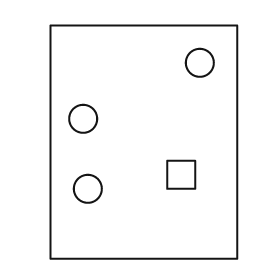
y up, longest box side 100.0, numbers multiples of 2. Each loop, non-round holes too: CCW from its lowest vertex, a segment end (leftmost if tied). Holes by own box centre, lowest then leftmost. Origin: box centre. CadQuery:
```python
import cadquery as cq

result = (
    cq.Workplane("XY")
    .moveTo(-40.0, -50.0)
    .lineTo(40.0, -50.0)
    .lineTo(40.0, 50.0)
    .lineTo(-40.0, 50.0)
    .close()
    .moveTo(-24.0, -20.0)
    .circle(6.0)
    .moveTo(10.0, -20.0)
    .lineTo(22.0, -20.0)
    .lineTo(22.0, -8.0)
    .lineTo(10.0, -8.0)
    .close()
    .moveTo(-26.0, 10.0)
    .circle(6.0)
    .moveTo(24.0, 34.0)
    .circle(6.0)
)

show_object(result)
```